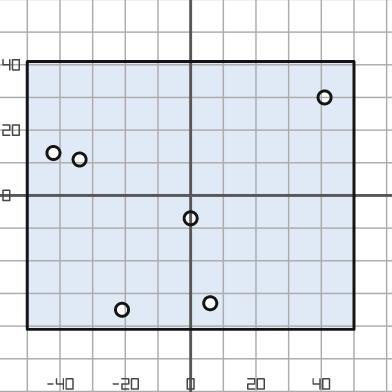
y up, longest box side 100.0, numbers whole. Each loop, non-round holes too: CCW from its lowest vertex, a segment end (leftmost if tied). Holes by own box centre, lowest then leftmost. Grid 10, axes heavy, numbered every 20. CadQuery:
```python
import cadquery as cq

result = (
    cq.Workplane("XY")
    .moveTo(-50.0, -41.0)
    .lineTo(50.0, -41.0)
    .lineTo(50.0, 41.0)
    .lineTo(-50.0, 41.0)
    .close()
    .moveTo(-21.0, -35.0)
    .circle(2.0)
    .moveTo(6.0, -33.0)
    .circle(2.0)
    .moveTo(0.0, -7.0)
    .circle(2.0)
    .moveTo(-34.0, 11.0)
    .circle(2.0)
    .moveTo(-42.0, 13.0)
    .circle(2.0)
    .moveTo(41.0, 30.0)
    .circle(2.0)
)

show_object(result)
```